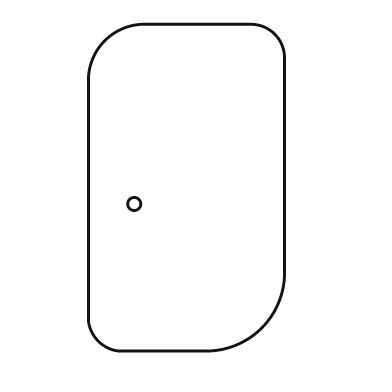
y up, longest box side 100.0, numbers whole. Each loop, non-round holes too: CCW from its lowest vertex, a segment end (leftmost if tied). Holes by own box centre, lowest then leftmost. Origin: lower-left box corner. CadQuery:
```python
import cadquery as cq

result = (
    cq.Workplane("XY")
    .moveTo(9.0, 0.0)
    .lineTo(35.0, 0.0)
    .threePointArc((53.0, 7.0), (60.0, 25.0))
    .lineTo(60.0, 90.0)
    .threePointArc((57.0, 97.0), (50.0, 100.0))
    .lineTo(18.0, 100.0)
    .threePointArc((5.0, 95.0), (0.0, 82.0))
    .lineTo(0.0, 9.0)
    .threePointArc((3.0, 3.0), (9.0, 0.0))
    .close()
    .moveTo(14.0, 45.0)
    .circle(2.0)
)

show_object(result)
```